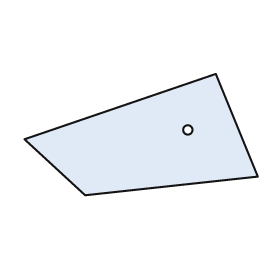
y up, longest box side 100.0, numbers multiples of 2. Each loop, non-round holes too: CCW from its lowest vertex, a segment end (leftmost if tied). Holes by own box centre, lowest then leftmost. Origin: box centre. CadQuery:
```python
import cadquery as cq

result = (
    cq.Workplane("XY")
    .moveTo(-24.0, -26.0)
    .lineTo(50.0, -18.0)
    .lineTo(32.0, 26.0)
    .lineTo(-50.0, -2.0)
    .close()
    .moveTo(20.0, 2.0)
    .circle(2.0)
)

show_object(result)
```